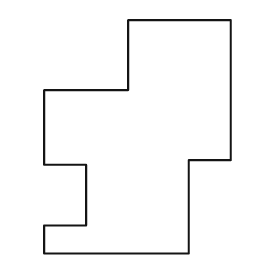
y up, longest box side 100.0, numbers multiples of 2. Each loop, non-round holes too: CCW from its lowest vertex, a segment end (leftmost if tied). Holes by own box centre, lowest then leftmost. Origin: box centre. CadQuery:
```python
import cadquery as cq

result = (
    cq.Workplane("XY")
    .moveTo(-40.0, -50.0)
    .lineTo(22.0, -50.0)
    .lineTo(22.0, -10.0)
    .lineTo(40.0, -10.0)
    .lineTo(40.0, 50.0)
    .lineTo(-4.0, 50.0)
    .lineTo(-4.0, 20.0)
    .lineTo(-40.0, 20.0)
    .lineTo(-40.0, -12.0)
    .lineTo(-22.0, -12.0)
    .lineTo(-22.0, -38.0)
    .lineTo(-40.0, -38.0)
    .close()
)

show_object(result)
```